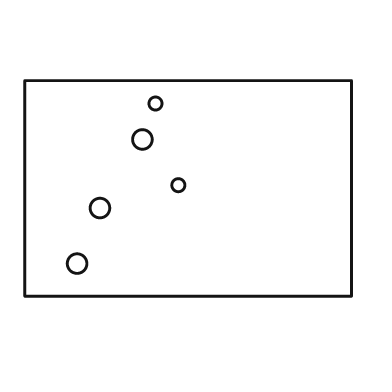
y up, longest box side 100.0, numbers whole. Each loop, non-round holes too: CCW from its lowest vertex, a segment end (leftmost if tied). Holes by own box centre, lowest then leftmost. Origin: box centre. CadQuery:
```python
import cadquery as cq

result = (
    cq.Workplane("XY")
    .moveTo(-50.0, -33.0)
    .lineTo(50.0, -33.0)
    .lineTo(50.0, 33.0)
    .lineTo(-50.0, 33.0)
    .close()
    .moveTo(-34.0, -23.0)
    .circle(3.0)
    .moveTo(-27.0, -6.0)
    .circle(3.0)
    .moveTo(-3.0, 1.0)
    .circle(2.0)
    .moveTo(-14.0, 15.0)
    .circle(3.0)
    .moveTo(-10.0, 26.0)
    .circle(2.0)
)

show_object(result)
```